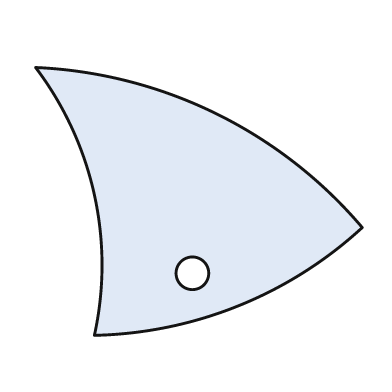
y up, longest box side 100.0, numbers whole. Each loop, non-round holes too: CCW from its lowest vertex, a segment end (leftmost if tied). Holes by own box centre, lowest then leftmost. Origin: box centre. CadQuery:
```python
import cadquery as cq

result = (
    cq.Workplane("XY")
    .moveTo(-32.0, -41.0)
    .threePointArc((12.0, -32.0), (50.0, -8.0))
    .threePointArc((5.0, 27.0), (-50.0, 41.0))
    .threePointArc((-32.0, 2.0), (-32.0, -41.0))
    .close()
    .moveTo(-2.0, -22.0)
    .circle(5.0)
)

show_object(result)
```